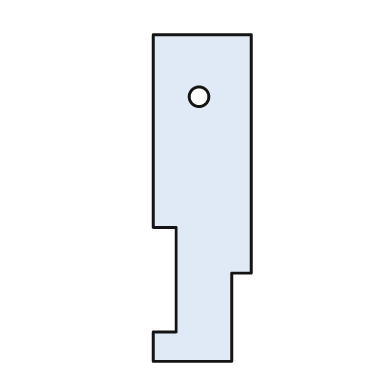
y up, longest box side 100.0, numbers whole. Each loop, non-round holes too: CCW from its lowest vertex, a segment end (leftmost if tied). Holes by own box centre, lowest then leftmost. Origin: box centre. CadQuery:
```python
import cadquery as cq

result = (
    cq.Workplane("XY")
    .moveTo(-15.0, -50.0)
    .lineTo(9.0, -50.0)
    .lineTo(9.0, -23.0)
    .lineTo(15.0, -23.0)
    .lineTo(15.0, 50.0)
    .lineTo(-15.0, 50.0)
    .lineTo(-15.0, -9.0)
    .lineTo(-8.0, -9.0)
    .lineTo(-8.0, -41.0)
    .lineTo(-15.0, -41.0)
    .close()
    .moveTo(-1.0, 31.0)
    .circle(3.0)
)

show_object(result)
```